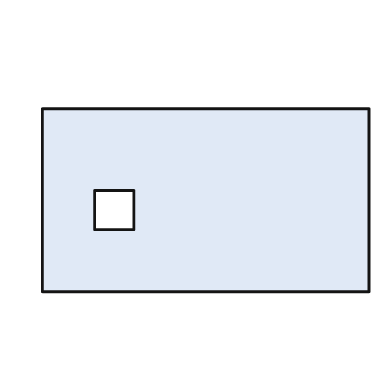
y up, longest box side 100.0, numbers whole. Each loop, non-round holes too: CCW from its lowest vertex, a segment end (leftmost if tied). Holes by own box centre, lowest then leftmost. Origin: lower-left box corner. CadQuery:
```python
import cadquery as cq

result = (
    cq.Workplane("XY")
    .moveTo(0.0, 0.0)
    .lineTo(100.0, 0.0)
    .lineTo(100.0, 56.0)
    .lineTo(0.0, 56.0)
    .close()
    .moveTo(16.0, 19.0)
    .lineTo(28.0, 19.0)
    .lineTo(28.0, 31.0)
    .lineTo(16.0, 31.0)
    .close()
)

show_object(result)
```